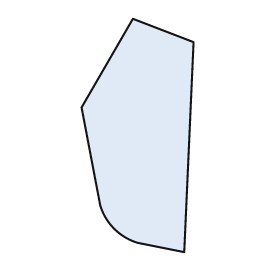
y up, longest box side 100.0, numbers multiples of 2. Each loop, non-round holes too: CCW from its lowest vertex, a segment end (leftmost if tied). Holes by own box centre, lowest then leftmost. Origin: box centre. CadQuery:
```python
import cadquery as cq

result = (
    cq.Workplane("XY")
    .moveTo(20.0, -50.0)
    .lineTo(24.0, 40.0)
    .lineTo(-2.0, 50.0)
    .lineTo(-24.0, 12.0)
    .lineTo(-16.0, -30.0)
    .threePointArc((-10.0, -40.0), (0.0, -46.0))
    .close()
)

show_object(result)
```